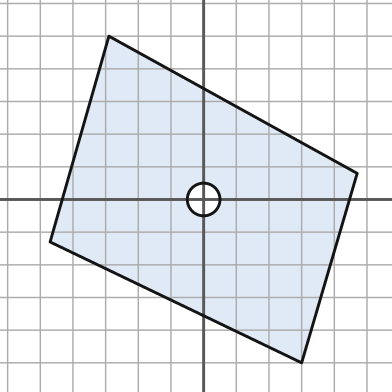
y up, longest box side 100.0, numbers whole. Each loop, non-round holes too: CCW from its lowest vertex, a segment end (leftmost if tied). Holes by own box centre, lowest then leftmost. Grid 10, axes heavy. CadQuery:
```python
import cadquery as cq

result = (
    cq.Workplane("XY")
    .moveTo(30.0, -50.0)
    .lineTo(47.0, 8.0)
    .lineTo(-29.0, 50.0)
    .lineTo(-47.0, -13.0)
    .close()
    .moveTo(0.0, 0.0)
    .circle(5.0)
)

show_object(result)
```